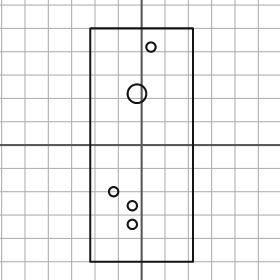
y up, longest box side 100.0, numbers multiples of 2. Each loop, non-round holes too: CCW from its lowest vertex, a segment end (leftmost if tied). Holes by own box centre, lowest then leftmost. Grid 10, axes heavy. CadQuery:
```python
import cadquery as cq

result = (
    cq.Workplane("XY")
    .moveTo(-22.0, -50.0)
    .lineTo(22.0, -50.0)
    .lineTo(22.0, 50.0)
    .lineTo(-22.0, 50.0)
    .close()
    .moveTo(-4.0, -34.0)
    .circle(2.0)
    .moveTo(-4.0, -26.0)
    .circle(2.0)
    .moveTo(-12.0, -20.0)
    .circle(2.0)
    .moveTo(-2.0, 22.0)
    .circle(4.0)
    .moveTo(4.0, 42.0)
    .circle(2.0)
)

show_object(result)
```